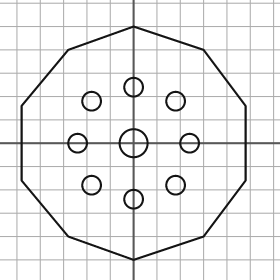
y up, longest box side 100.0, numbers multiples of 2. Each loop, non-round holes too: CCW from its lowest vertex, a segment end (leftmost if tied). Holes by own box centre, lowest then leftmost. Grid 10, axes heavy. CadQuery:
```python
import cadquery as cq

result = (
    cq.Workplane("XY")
    .moveTo(0.0, -50.0)
    .lineTo(30.0, -40.0)
    .lineTo(48.0, -16.0)
    .lineTo(48.0, 16.0)
    .lineTo(30.0, 40.0)
    .lineTo(0.0, 50.0)
    .lineTo(-28.0, 40.0)
    .lineTo(-48.0, 16.0)
    .lineTo(-48.0, -16.0)
    .lineTo(-28.0, -40.0)
    .close()
    .moveTo(0.0, -24.0)
    .circle(4.0)
    .moveTo(-18.0, -18.0)
    .circle(4.0)
    .moveTo(18.0, -18.0)
    .circle(4.0)
    .moveTo(-24.0, 0.0)
    .circle(4.0)
    .moveTo(0.0, 0.0)
    .circle(6.0)
    .moveTo(24.0, 0.0)
    .circle(4.0)
    .moveTo(-18.0, 18.0)
    .circle(4.0)
    .moveTo(18.0, 18.0)
    .circle(4.0)
    .moveTo(0.0, 24.0)
    .circle(4.0)
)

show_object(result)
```